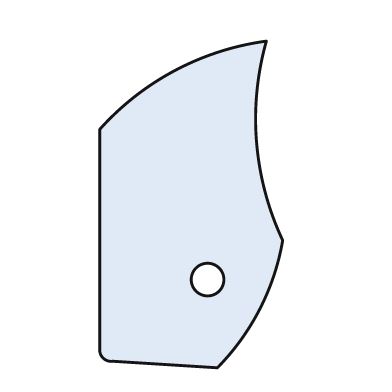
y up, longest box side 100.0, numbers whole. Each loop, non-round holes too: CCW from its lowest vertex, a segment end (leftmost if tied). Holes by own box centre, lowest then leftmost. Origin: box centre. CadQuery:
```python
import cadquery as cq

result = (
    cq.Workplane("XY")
    .moveTo(8.0, -50.0)
    .threePointArc((21.0, -32.0), (28.0, -11.0))
    .threePointArc((20.0, 19.0), (23.0, 50.0))
    .threePointArc((-5.0, 41.0), (-28.0, 23.0))
    .lineTo(-28.0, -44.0)
    .threePointArc((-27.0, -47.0), (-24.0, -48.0))
    .close()
    .moveTo(5.0, -23.0)
    .circle(5.0)
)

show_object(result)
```